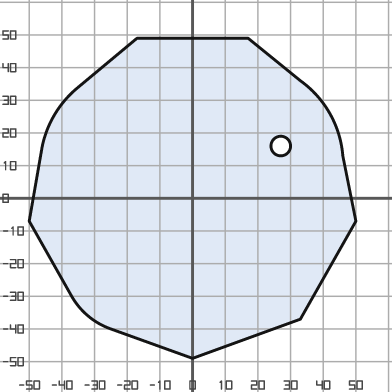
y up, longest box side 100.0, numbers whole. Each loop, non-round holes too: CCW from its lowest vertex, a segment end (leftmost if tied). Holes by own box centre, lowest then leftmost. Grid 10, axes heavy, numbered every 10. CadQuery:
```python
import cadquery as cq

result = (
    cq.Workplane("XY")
    .moveTo(0.0, -49.0)
    .lineTo(33.0, -37.0)
    .lineTo(50.0, -7.0)
    .lineTo(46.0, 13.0)
    .threePointArc((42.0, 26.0), (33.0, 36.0))
    .lineTo(17.0, 49.0)
    .lineTo(-17.0, 49.0)
    .lineTo(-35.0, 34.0)
    .threePointArc((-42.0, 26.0), (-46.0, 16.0))
    .lineTo(-50.0, -7.0)
    .lineTo(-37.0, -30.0)
    .threePointArc((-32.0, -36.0), (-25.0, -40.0))
    .close()
    .moveTo(27.0, 16.0)
    .circle(3.0)
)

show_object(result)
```